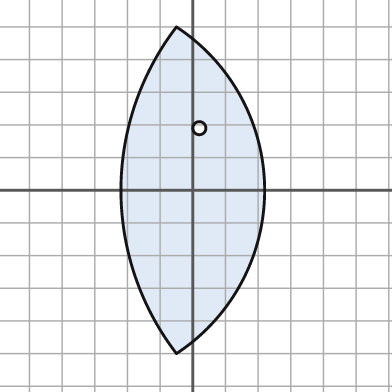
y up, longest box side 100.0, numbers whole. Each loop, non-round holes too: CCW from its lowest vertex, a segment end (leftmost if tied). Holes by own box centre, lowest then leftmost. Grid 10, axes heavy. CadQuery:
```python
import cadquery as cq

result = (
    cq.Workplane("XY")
    .moveTo(-5.0, -50.0)
    .threePointArc((22.0, 0.0), (-5.0, 50.0))
    .threePointArc((-22.0, 0.0), (-5.0, -50.0))
    .close()
    .moveTo(2.0, 19.0)
    .circle(2.0)
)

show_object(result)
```